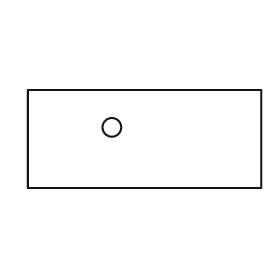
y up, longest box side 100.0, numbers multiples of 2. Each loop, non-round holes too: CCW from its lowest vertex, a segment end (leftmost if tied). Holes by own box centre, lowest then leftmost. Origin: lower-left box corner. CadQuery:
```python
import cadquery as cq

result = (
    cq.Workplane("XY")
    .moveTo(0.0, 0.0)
    .lineTo(100.0, 0.0)
    .lineTo(100.0, 42.0)
    .lineTo(0.0, 42.0)
    .close()
    .moveTo(36.0, 26.0)
    .circle(4.0)
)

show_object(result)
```